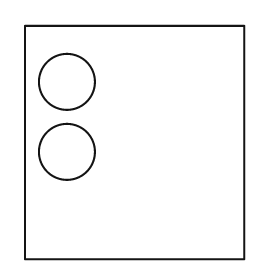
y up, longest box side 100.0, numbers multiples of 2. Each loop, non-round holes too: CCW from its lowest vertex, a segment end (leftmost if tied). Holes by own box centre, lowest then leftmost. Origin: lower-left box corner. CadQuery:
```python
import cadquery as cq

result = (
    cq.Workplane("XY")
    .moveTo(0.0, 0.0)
    .lineTo(94.0, 0.0)
    .lineTo(94.0, 100.0)
    .lineTo(0.0, 100.0)
    .close()
    .moveTo(18.0, 46.0)
    .circle(12.0)
    .moveTo(18.0, 76.0)
    .circle(12.0)
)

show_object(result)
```